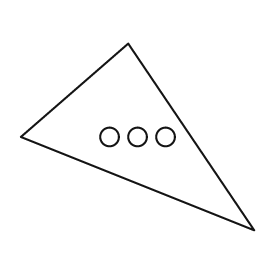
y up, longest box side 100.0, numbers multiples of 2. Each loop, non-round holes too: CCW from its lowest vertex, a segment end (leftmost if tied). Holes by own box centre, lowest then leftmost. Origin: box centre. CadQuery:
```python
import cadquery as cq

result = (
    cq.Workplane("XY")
    .moveTo(50.0, -40.0)
    .lineTo(-4.0, 40.0)
    .lineTo(-50.0, 0.0)
    .close()
    .moveTo(-12.0, 0.0)
    .circle(4.0)
    .moveTo(0.0, 0.0)
    .circle(4.0)
    .moveTo(12.0, 0.0)
    .circle(4.0)
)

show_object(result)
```